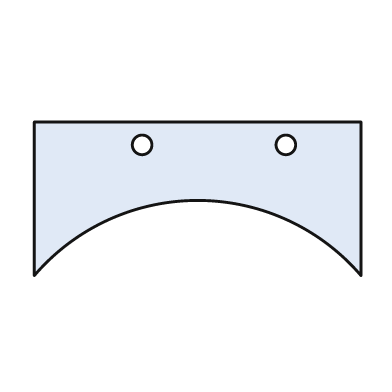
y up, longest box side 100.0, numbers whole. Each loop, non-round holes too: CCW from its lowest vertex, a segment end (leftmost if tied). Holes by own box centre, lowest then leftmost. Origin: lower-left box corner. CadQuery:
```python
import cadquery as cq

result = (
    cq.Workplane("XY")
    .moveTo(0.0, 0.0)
    .threePointArc((50.0, 23.0), (100.0, 0.0))
    .lineTo(100.0, 47.0)
    .lineTo(0.0, 47.0)
    .close()
    .moveTo(33.0, 40.0)
    .circle(3.0)
    .moveTo(77.0, 40.0)
    .circle(3.0)
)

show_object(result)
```